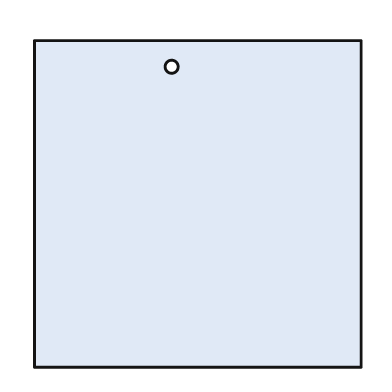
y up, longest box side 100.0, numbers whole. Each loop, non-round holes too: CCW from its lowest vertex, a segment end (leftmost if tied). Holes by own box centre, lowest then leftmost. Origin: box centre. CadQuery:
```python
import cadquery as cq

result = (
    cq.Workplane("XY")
    .moveTo(-50.0, -50.0)
    .lineTo(50.0, -50.0)
    .lineTo(50.0, 50.0)
    .lineTo(-50.0, 50.0)
    .close()
    .moveTo(-8.0, 42.0)
    .circle(2.0)
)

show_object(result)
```